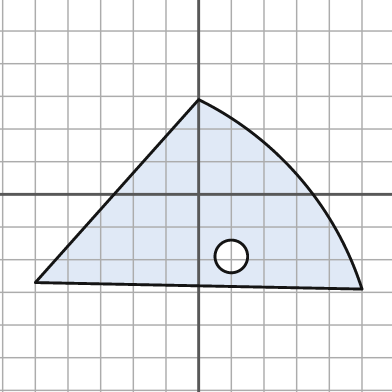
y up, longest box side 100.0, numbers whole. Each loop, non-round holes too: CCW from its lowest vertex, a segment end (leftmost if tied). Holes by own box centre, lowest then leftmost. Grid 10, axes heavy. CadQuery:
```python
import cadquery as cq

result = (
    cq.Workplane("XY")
    .moveTo(50.0, -29.0)
    .threePointArc((31.0, 5.0), (0.0, 29.0))
    .lineTo(-50.0, -27.0)
    .close()
    .moveTo(10.0, -19.0)
    .circle(5.0)
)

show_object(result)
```